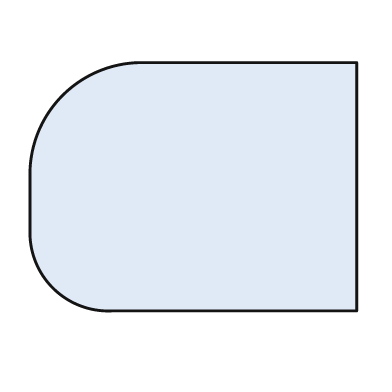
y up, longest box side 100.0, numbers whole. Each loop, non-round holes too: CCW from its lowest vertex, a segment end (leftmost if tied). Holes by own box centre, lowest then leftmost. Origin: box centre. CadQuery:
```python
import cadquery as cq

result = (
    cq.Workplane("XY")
    .moveTo(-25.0, -38.0)
    .lineTo(50.0, -38.0)
    .lineTo(50.0, 38.0)
    .lineTo(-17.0, 38.0)
    .threePointArc((-40.0, 28.0), (-50.0, 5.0))
    .lineTo(-50.0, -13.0)
    .threePointArc((-43.0, -31.0), (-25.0, -38.0))
    .close()
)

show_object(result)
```